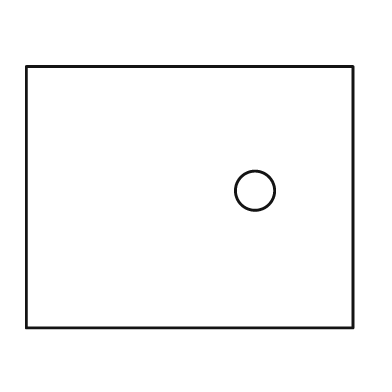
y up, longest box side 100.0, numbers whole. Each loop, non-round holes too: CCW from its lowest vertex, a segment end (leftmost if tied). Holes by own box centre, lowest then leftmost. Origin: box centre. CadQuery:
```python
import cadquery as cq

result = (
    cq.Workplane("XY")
    .moveTo(-50.0, -40.0)
    .lineTo(50.0, -40.0)
    .lineTo(50.0, 40.0)
    .lineTo(-50.0, 40.0)
    .close()
    .moveTo(20.0, 2.0)
    .circle(6.0)
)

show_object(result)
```